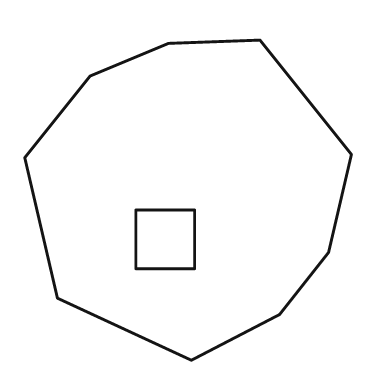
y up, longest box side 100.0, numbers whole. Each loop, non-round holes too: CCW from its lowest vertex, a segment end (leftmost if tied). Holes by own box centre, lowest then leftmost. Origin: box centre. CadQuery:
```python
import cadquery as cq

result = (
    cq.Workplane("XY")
    .moveTo(1.0, -49.0)
    .lineTo(28.0, -35.0)
    .lineTo(43.0, -16.0)
    .lineTo(50.0, 14.0)
    .lineTo(22.0, 49.0)
    .lineTo(-6.0, 48.0)
    .lineTo(-30.0, 38.0)
    .lineTo(-50.0, 13.0)
    .lineTo(-40.0, -30.0)
    .close()
    .moveTo(-16.0, -21.0)
    .lineTo(2.0, -21.0)
    .lineTo(2.0, -3.0)
    .lineTo(-16.0, -3.0)
    .close()
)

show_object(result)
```